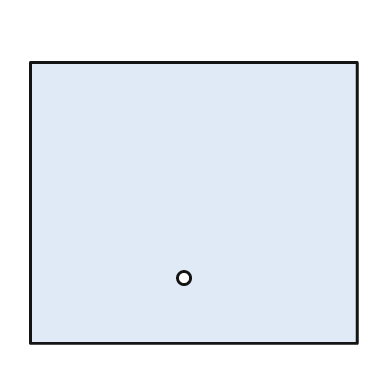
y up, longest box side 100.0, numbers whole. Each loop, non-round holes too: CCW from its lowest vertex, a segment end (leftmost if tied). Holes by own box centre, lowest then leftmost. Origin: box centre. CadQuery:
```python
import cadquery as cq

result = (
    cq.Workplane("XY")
    .moveTo(-50.0, -43.0)
    .lineTo(50.0, -43.0)
    .lineTo(50.0, 43.0)
    .lineTo(-50.0, 43.0)
    .close()
    .moveTo(-3.0, -23.0)
    .circle(2.0)
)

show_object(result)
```